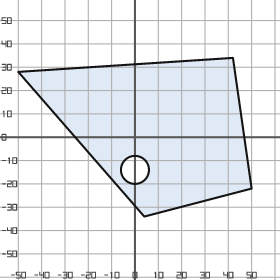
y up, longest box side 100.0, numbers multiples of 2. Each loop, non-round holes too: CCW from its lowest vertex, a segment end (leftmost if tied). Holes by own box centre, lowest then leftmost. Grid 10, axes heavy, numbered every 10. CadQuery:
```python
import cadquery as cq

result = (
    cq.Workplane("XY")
    .moveTo(4.0, -34.0)
    .lineTo(50.0, -22.0)
    .lineTo(42.0, 34.0)
    .lineTo(-50.0, 28.0)
    .close()
    .moveTo(0.0, -14.0)
    .circle(6.0)
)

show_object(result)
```